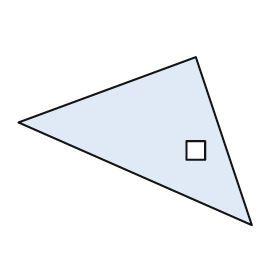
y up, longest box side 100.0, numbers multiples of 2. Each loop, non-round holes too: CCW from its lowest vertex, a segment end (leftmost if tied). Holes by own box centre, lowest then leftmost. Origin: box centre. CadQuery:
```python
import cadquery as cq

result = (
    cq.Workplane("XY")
    .moveTo(50.0, -36.0)
    .lineTo(26.0, 36.0)
    .lineTo(-50.0, 8.0)
    .close()
    .moveTo(22.0, -8.0)
    .lineTo(30.0, -8.0)
    .lineTo(30.0, 0.0)
    .lineTo(22.0, 0.0)
    .close()
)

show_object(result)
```